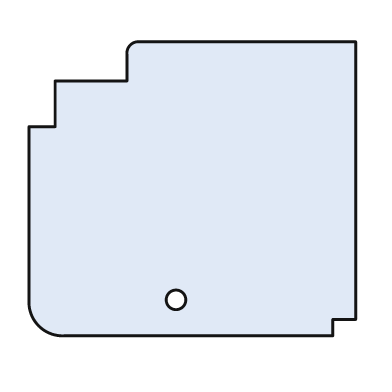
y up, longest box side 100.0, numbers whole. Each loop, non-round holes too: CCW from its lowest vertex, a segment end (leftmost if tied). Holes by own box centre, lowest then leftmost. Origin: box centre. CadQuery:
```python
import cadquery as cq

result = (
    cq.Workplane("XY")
    .moveTo(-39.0, -45.0)
    .lineTo(43.0, -45.0)
    .lineTo(43.0, -40.0)
    .lineTo(50.0, -40.0)
    .lineTo(50.0, 45.0)
    .lineTo(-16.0, 45.0)
    .threePointArc((-19.0, 44.0), (-20.0, 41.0))
    .lineTo(-20.0, 33.0)
    .lineTo(-42.0, 33.0)
    .lineTo(-42.0, 19.0)
    .lineTo(-50.0, 19.0)
    .lineTo(-50.0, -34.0)
    .threePointArc((-47.0, -42.0), (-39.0, -45.0))
    .close()
    .moveTo(-5.0, -34.0)
    .circle(3.0)
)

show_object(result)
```